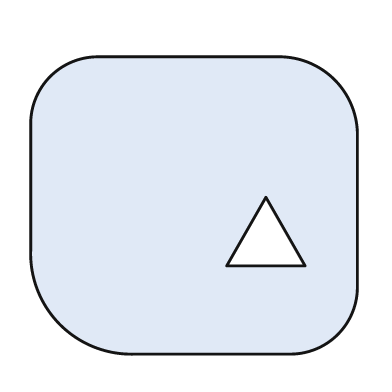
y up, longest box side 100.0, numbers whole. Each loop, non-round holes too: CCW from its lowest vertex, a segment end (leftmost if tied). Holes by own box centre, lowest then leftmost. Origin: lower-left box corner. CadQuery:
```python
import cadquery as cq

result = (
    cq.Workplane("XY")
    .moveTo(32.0, 0.0)
    .lineTo(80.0, 0.0)
    .threePointArc((94.0, 6.0), (100.0, 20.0))
    .lineTo(100.0, 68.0)
    .threePointArc((93.0, 84.0), (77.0, 91.0))
    .lineTo(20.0, 91.0)
    .threePointArc((6.0, 85.0), (0.0, 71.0))
    .lineTo(0.0, 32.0)
    .threePointArc((9.0, 9.0), (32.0, 0.0))
    .close()
    .moveTo(60.0, 27.0)
    .lineTo(84.0, 27.0)
    .lineTo(72.0, 48.0)
    .close()
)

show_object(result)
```